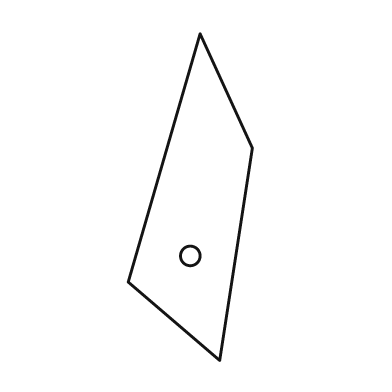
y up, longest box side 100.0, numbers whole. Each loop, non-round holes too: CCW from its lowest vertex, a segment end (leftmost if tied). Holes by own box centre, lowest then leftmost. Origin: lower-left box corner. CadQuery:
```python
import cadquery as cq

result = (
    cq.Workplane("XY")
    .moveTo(28.0, 0.0)
    .lineTo(38.0, 65.0)
    .lineTo(22.0, 100.0)
    .lineTo(0.0, 24.0)
    .close()
    .moveTo(19.0, 32.0)
    .circle(3.0)
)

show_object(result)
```